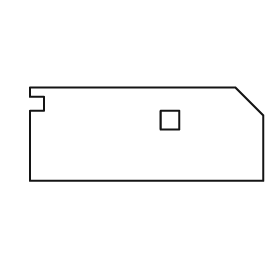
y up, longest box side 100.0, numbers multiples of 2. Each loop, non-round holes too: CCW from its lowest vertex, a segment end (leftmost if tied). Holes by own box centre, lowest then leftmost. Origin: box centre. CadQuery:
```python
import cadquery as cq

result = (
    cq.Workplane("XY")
    .moveTo(-50.0, -20.0)
    .lineTo(50.0, -20.0)
    .lineTo(50.0, 8.0)
    .lineTo(38.0, 20.0)
    .lineTo(-50.0, 20.0)
    .lineTo(-50.0, 16.0)
    .lineTo(-44.0, 16.0)
    .lineTo(-44.0, 10.0)
    .lineTo(-50.0, 10.0)
    .close()
    .moveTo(6.0, 2.0)
    .lineTo(14.0, 2.0)
    .lineTo(14.0, 10.0)
    .lineTo(6.0, 10.0)
    .close()
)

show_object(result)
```